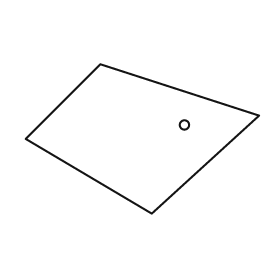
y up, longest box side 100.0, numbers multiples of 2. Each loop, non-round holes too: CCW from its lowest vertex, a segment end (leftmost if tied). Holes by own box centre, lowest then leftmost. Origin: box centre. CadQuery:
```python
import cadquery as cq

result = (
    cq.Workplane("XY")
    .moveTo(4.0, -32.0)
    .lineTo(50.0, 10.0)
    .lineTo(-18.0, 32.0)
    .lineTo(-50.0, 0.0)
    .close()
    .moveTo(18.0, 6.0)
    .circle(2.0)
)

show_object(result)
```